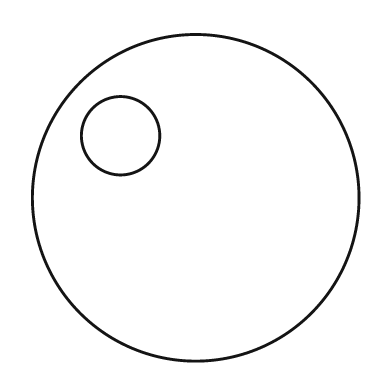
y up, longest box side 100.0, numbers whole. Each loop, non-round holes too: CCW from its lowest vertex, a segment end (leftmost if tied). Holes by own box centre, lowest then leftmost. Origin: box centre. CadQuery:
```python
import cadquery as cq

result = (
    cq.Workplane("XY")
    .moveTo(0.0, 0.0)
    .circle(50.0)
    .moveTo(-23.0, 19.0)
    .circle(12.0)
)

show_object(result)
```